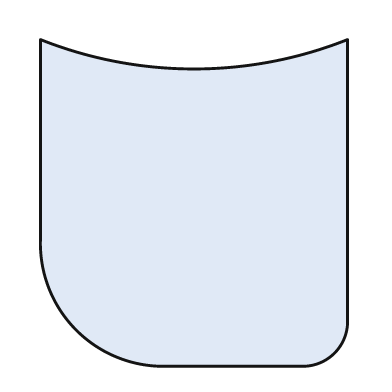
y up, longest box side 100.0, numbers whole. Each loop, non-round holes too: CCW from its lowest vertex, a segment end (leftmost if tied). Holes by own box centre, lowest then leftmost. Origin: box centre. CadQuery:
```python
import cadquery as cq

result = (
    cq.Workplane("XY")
    .moveTo(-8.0, -50.0)
    .lineTo(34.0, -50.0)
    .threePointArc((43.0, -46.0), (47.0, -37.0))
    .lineTo(47.0, 50.0)
    .threePointArc((0.0, 41.0), (-47.0, 50.0))
    .lineTo(-47.0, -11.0)
    .threePointArc((-36.0, -39.0), (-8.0, -50.0))
    .close()
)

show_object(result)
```